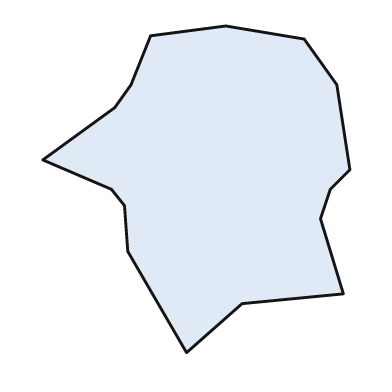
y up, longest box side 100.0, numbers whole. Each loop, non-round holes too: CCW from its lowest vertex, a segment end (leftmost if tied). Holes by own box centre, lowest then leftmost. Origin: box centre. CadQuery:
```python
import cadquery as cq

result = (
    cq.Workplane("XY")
    .moveTo(-3.0, -50.0)
    .lineTo(14.0, -35.0)
    .lineTo(45.0, -32.0)
    .lineTo(38.0, -9.0)
    .lineTo(41.0, 0.0)
    .lineTo(47.0, 6.0)
    .lineTo(43.0, 32.0)
    .lineTo(33.0, 46.0)
    .lineTo(9.0, 50.0)
    .lineTo(-14.0, 47.0)
    .lineTo(-20.0, 32.0)
    .lineTo(-25.0, 25.0)
    .lineTo(-47.0, 9.0)
    .lineTo(-26.0, 0.0)
    .lineTo(-22.0, -5.0)
    .lineTo(-21.0, -19.0)
    .close()
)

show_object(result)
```